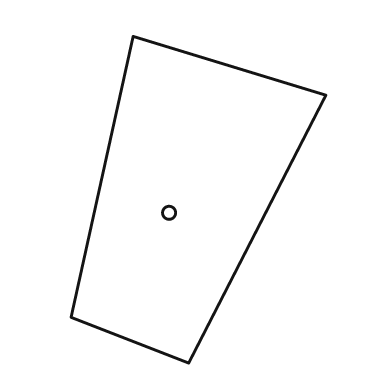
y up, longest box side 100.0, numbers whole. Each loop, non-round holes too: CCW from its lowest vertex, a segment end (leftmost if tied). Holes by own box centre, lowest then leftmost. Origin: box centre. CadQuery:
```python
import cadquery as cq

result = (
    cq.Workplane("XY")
    .moveTo(-3.0, -50.0)
    .lineTo(39.0, 32.0)
    .lineTo(-20.0, 50.0)
    .lineTo(-39.0, -36.0)
    .close()
    .moveTo(-9.0, -4.0)
    .circle(2.0)
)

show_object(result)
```